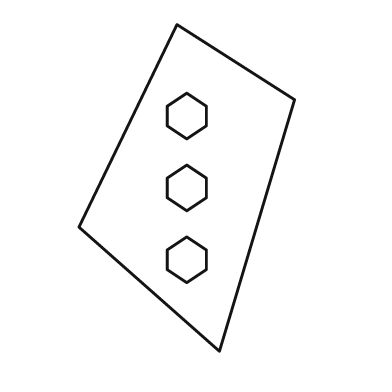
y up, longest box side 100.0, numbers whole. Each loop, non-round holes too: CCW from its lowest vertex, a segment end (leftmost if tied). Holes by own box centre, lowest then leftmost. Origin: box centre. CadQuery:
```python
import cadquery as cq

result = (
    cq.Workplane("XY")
    .moveTo(10.0, -50.0)
    .lineTo(33.0, 27.0)
    .lineTo(-3.0, 50.0)
    .lineTo(-33.0, -12.0)
    .close()
    .moveTo(0.0, -29.0)
    .lineTo(6.0, -25.0)
    .lineTo(6.0, -19.0)
    .lineTo(0.0, -15.0)
    .lineTo(-6.0, -19.0)
    .lineTo(-6.0, -25.0)
    .close()
    .moveTo(0.0, -7.0)
    .lineTo(6.0, -3.0)
    .lineTo(6.0, 3.0)
    .lineTo(0.0, 7.0)
    .lineTo(-6.0, 3.0)
    .lineTo(-6.0, -3.0)
    .close()
    .moveTo(0.0, 15.0)
    .lineTo(6.0, 19.0)
    .lineTo(6.0, 25.0)
    .lineTo(0.0, 29.0)
    .lineTo(-6.0, 25.0)
    .lineTo(-6.0, 19.0)
    .close()
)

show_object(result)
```